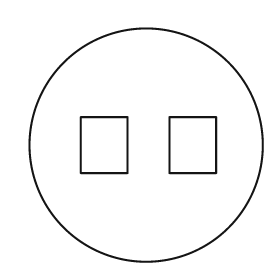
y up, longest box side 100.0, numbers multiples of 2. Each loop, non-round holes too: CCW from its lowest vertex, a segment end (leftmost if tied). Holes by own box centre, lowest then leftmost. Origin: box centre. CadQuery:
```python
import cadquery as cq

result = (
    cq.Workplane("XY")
    .moveTo(0.0, 0.0)
    .circle(50.0)
    .moveTo(-28.0, -12.0)
    .lineTo(-8.0, -12.0)
    .lineTo(-8.0, 12.0)
    .lineTo(-28.0, 12.0)
    .close()
    .moveTo(10.0, -12.0)
    .lineTo(30.0, -12.0)
    .lineTo(30.0, 12.0)
    .lineTo(10.0, 12.0)
    .close()
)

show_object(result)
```